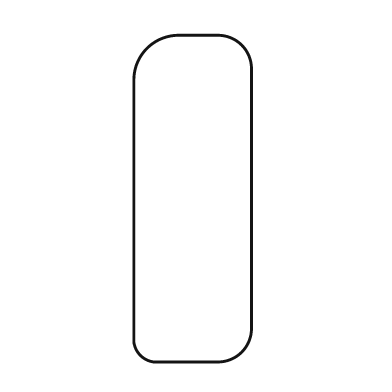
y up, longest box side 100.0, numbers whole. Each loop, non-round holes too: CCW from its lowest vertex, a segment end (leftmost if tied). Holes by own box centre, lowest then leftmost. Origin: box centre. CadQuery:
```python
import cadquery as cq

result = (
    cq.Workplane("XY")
    .moveTo(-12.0, -50.0)
    .lineTo(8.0, -50.0)
    .threePointArc((15.0, -47.0), (18.0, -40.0))
    .lineTo(18.0, 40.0)
    .threePointArc((15.0, 47.0), (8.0, 50.0))
    .lineTo(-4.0, 50.0)
    .threePointArc((-14.0, 46.0), (-18.0, 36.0))
    .lineTo(-18.0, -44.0)
    .threePointArc((-16.0, -48.0), (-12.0, -50.0))
    .close()
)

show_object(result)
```